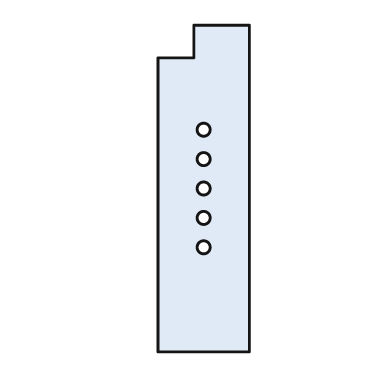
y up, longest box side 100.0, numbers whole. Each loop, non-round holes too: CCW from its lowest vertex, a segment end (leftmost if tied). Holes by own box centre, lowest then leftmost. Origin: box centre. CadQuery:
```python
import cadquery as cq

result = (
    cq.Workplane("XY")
    .moveTo(-14.0, -50.0)
    .lineTo(14.0, -50.0)
    .lineTo(14.0, 50.0)
    .lineTo(-3.0, 50.0)
    .lineTo(-3.0, 40.0)
    .lineTo(-14.0, 40.0)
    .close()
    .moveTo(0.0, -18.0)
    .circle(2.0)
    .moveTo(0.0, -9.0)
    .circle(2.0)
    .moveTo(0.0, 0.0)
    .circle(2.0)
    .moveTo(0.0, 9.0)
    .circle(2.0)
    .moveTo(0.0, 18.0)
    .circle(2.0)
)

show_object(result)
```